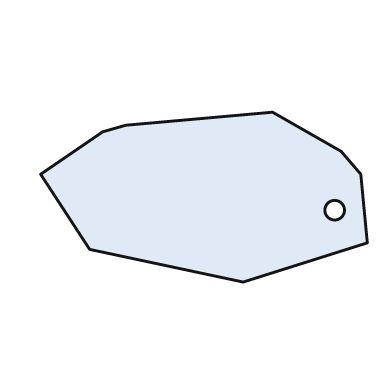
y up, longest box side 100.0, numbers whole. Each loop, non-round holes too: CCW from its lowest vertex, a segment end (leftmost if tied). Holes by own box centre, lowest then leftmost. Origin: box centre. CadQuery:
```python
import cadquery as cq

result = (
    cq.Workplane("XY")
    .moveTo(12.0, -26.0)
    .lineTo(50.0, -14.0)
    .lineTo(48.0, 7.0)
    .lineTo(42.0, 14.0)
    .lineTo(21.0, 26.0)
    .lineTo(-24.0, 22.0)
    .lineTo(-31.0, 20.0)
    .lineTo(-50.0, 7.0)
    .lineTo(-35.0, -16.0)
    .close()
    .moveTo(40.0, -4.0)
    .circle(3.0)
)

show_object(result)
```